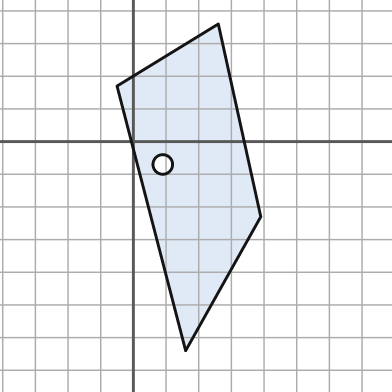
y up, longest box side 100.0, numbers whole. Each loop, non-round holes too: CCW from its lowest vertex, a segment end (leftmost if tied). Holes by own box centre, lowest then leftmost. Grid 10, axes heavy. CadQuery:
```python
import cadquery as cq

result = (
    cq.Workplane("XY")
    .moveTo(16.0, -64.0)
    .lineTo(39.0, -23.0)
    .lineTo(26.0, 36.0)
    .lineTo(-5.0, 17.0)
    .close()
    .moveTo(9.0, -7.0)
    .circle(3.0)
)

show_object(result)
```